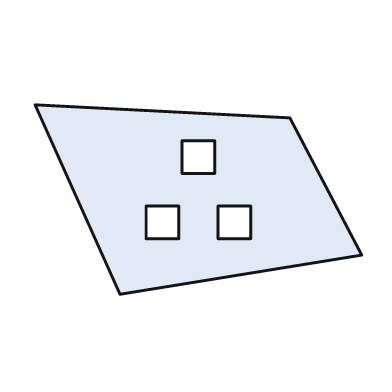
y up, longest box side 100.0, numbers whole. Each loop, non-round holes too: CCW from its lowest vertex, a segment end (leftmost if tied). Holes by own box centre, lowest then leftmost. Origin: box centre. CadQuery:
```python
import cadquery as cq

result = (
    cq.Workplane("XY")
    .moveTo(-24.0, -29.0)
    .lineTo(50.0, -17.0)
    .lineTo(28.0, 25.0)
    .lineTo(-50.0, 29.0)
    .close()
    .moveTo(-16.0, -12.0)
    .lineTo(-6.0, -12.0)
    .lineTo(-6.0, -2.0)
    .lineTo(-16.0, -2.0)
    .close()
    .moveTo(6.0, -12.0)
    .lineTo(16.0, -12.0)
    .lineTo(16.0, -2.0)
    .lineTo(6.0, -2.0)
    .close()
    .moveTo(-5.0, 8.0)
    .lineTo(5.0, 8.0)
    .lineTo(5.0, 18.0)
    .lineTo(-5.0, 18.0)
    .close()
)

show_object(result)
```